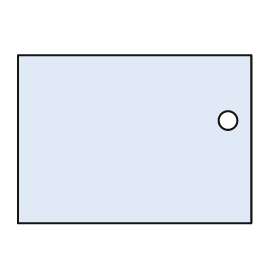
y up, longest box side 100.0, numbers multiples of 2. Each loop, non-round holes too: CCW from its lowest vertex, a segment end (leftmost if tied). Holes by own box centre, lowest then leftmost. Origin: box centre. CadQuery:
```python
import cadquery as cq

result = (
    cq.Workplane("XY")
    .moveTo(-50.0, -36.0)
    .lineTo(50.0, -36.0)
    .lineTo(50.0, 36.0)
    .lineTo(-50.0, 36.0)
    .close()
    .moveTo(40.0, 8.0)
    .circle(4.0)
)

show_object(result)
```